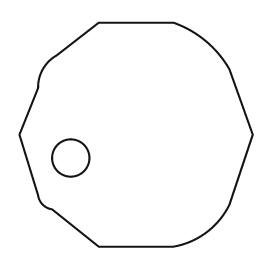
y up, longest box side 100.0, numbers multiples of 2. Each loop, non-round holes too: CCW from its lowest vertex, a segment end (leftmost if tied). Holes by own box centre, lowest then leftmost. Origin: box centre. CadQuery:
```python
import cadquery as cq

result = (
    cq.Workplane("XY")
    .moveTo(-16.0, -48.0)
    .lineTo(16.0, -48.0)
    .threePointArc((30.0, -42.0), (40.0, -30.0))
    .lineTo(50.0, 0.0)
    .lineTo(40.0, 28.0)
    .threePointArc((30.0, 40.0), (16.0, 48.0))
    .lineTo(-16.0, 48.0)
    .lineTo(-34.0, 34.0)
    .threePointArc((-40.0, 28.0), (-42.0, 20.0))
    .lineTo(-50.0, 0.0)
    .lineTo(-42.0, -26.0)
    .threePointArc((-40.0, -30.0), (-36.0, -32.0))
    .close()
    .moveTo(-28.0, -10.0)
    .circle(8.0)
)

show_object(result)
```